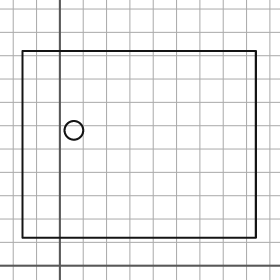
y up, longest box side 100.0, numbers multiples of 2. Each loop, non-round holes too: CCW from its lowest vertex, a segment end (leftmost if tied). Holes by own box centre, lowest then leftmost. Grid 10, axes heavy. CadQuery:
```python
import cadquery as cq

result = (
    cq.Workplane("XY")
    .moveTo(-16.0, 12.0)
    .lineTo(84.0, 12.0)
    .lineTo(84.0, 92.0)
    .lineTo(-16.0, 92.0)
    .close()
    .moveTo(6.0, 58.0)
    .circle(4.0)
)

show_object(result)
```